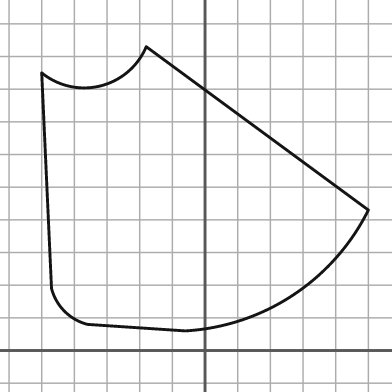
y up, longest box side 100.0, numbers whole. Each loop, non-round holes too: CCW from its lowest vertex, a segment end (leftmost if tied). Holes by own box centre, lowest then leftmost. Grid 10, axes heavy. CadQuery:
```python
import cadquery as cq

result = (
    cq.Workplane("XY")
    .moveTo(-6.0, 6.0)
    .threePointArc((27.0, 17.0), (50.0, 43.0))
    .lineTo(-18.0, 93.0)
    .threePointArc((-32.0, 81.0), (-50.0, 85.0))
    .lineTo(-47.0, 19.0)
    .threePointArc((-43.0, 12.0), (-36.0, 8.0))
    .close()
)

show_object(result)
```